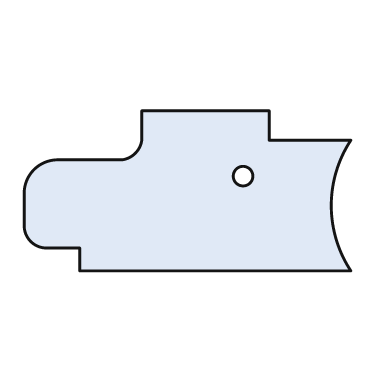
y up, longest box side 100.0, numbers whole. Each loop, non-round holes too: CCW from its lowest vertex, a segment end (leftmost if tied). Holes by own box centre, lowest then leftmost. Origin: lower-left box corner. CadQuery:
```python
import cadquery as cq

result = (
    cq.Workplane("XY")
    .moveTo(17.0, 0.0)
    .lineTo(100.0, 0.0)
    .threePointArc((94.0, 20.0), (100.0, 40.0))
    .lineTo(75.0, 40.0)
    .lineTo(75.0, 49.0)
    .lineTo(36.0, 49.0)
    .lineTo(36.0, 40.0)
    .threePointArc((34.0, 36.0), (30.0, 34.0))
    .lineTo(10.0, 34.0)
    .threePointArc((3.0, 31.0), (0.0, 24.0))
    .lineTo(0.0, 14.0)
    .threePointArc((2.0, 9.0), (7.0, 7.0))
    .lineTo(17.0, 7.0)
    .close()
    .moveTo(67.0, 29.0)
    .circle(3.0)
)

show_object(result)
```